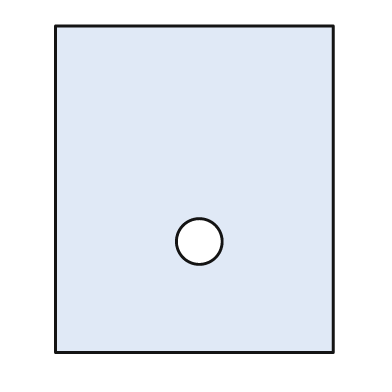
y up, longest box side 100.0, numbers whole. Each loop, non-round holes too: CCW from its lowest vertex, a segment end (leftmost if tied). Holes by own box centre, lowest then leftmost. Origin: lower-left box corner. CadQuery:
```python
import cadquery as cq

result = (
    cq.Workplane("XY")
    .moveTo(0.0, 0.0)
    .lineTo(85.0, 0.0)
    .lineTo(85.0, 100.0)
    .lineTo(0.0, 100.0)
    .close()
    .moveTo(44.0, 34.0)
    .circle(7.0)
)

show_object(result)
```